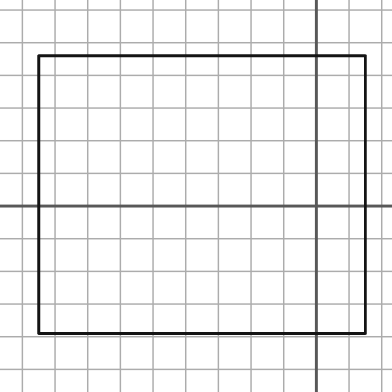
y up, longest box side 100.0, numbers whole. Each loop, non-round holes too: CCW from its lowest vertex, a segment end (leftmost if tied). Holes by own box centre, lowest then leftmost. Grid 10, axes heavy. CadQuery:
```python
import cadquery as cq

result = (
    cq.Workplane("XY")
    .moveTo(-85.0, -39.0)
    .lineTo(15.0, -39.0)
    .lineTo(15.0, 46.0)
    .lineTo(-85.0, 46.0)
    .close()
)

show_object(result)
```